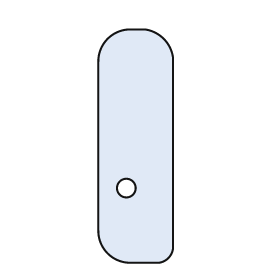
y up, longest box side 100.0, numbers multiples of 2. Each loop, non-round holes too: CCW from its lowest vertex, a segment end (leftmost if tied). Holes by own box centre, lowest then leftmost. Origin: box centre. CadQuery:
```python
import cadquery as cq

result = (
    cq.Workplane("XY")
    .moveTo(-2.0, -50.0)
    .lineTo(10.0, -50.0)
    .threePointArc((14.0, -48.0), (16.0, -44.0))
    .lineTo(16.0, 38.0)
    .threePointArc((12.0, 46.0), (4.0, 50.0))
    .lineTo(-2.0, 50.0)
    .threePointArc((-12.0, 46.0), (-16.0, 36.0))
    .lineTo(-16.0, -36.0)
    .threePointArc((-12.0, -46.0), (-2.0, -50.0))
    .close()
    .moveTo(-4.0, -18.0)
    .circle(4.0)
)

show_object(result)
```